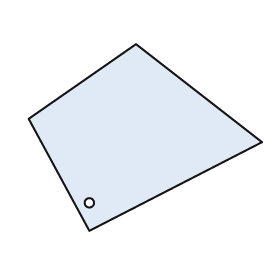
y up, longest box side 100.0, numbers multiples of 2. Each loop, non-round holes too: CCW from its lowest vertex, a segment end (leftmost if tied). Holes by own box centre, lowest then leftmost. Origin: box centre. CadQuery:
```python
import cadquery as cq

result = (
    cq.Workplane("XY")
    .moveTo(-24.0, -40.0)
    .lineTo(50.0, -2.0)
    .lineTo(-4.0, 40.0)
    .lineTo(-50.0, 8.0)
    .close()
    .moveTo(-24.0, -28.0)
    .circle(2.0)
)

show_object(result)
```